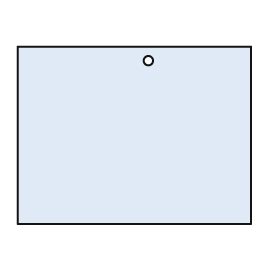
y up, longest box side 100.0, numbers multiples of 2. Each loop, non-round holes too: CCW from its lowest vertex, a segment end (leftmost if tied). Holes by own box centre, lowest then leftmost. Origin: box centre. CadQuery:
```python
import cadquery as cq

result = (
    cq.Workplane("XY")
    .moveTo(-50.0, -38.0)
    .lineTo(50.0, -38.0)
    .lineTo(50.0, 38.0)
    .lineTo(-50.0, 38.0)
    .close()
    .moveTo(6.0, 32.0)
    .circle(2.0)
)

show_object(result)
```